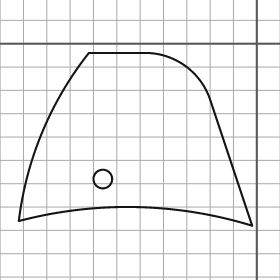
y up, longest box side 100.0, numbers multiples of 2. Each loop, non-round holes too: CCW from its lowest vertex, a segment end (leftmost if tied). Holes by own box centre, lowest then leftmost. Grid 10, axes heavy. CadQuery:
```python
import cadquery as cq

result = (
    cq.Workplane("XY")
    .moveTo(-2.0, -78.0)
    .lineTo(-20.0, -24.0)
    .threePointArc((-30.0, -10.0), (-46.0, -4.0))
    .lineTo(-72.0, -4.0)
    .threePointArc((-92.0, -38.0), (-102.0, -76.0))
    .threePointArc((-52.0, -70.0), (-2.0, -78.0))
    .close()
    .moveTo(-66.0, -58.0)
    .circle(4.0)
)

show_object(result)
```